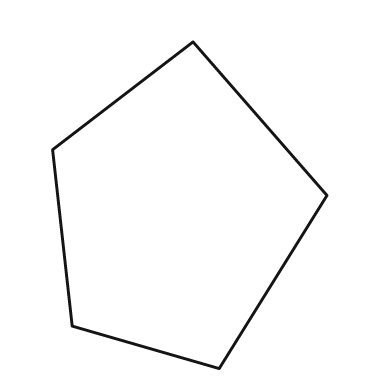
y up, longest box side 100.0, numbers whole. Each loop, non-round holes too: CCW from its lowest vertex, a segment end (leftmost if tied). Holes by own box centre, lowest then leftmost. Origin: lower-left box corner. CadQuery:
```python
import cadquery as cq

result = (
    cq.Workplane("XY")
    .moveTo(51.0, 0.0)
    .lineTo(84.0, 53.0)
    .lineTo(43.0, 100.0)
    .lineTo(0.0, 67.0)
    .lineTo(6.0, 13.0)
    .close()
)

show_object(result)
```